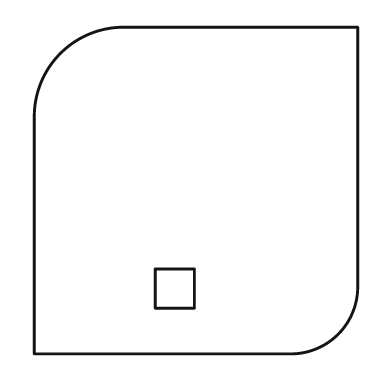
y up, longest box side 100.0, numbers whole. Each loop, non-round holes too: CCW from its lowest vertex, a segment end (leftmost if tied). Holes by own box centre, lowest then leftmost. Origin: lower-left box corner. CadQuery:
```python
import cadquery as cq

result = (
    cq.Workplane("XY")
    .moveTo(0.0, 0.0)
    .lineTo(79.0, 0.0)
    .threePointArc((93.0, 6.0), (99.0, 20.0))
    .lineTo(99.0, 100.0)
    .lineTo(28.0, 100.0)
    .threePointArc((8.0, 92.0), (0.0, 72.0))
    .close()
    .moveTo(37.0, 14.0)
    .lineTo(49.0, 14.0)
    .lineTo(49.0, 26.0)
    .lineTo(37.0, 26.0)
    .close()
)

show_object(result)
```